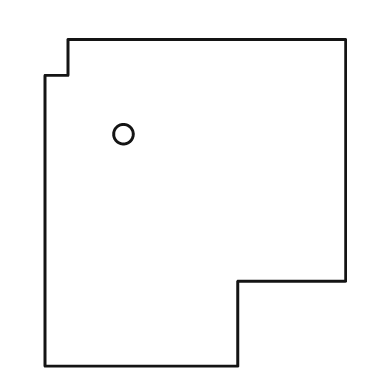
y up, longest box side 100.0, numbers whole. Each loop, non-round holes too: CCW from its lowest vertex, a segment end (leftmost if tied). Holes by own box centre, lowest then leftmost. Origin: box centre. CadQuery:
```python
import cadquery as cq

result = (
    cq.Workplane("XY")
    .moveTo(-46.0, -50.0)
    .lineTo(13.0, -50.0)
    .lineTo(13.0, -24.0)
    .lineTo(46.0, -24.0)
    .lineTo(46.0, 50.0)
    .lineTo(-39.0, 50.0)
    .lineTo(-39.0, 39.0)
    .lineTo(-46.0, 39.0)
    .close()
    .moveTo(-22.0, 21.0)
    .circle(3.0)
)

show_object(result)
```